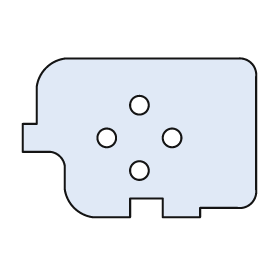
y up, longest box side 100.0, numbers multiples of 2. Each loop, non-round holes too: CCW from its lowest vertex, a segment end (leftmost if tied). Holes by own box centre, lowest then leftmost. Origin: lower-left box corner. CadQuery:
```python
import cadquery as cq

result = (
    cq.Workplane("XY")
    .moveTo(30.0, 0.0)
    .lineTo(46.0, 0.0)
    .lineTo(46.0, 8.0)
    .lineTo(60.0, 8.0)
    .lineTo(60.0, 0.0)
    .lineTo(76.0, 0.0)
    .lineTo(76.0, 4.0)
    .lineTo(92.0, 4.0)
    .threePointArc((98.0, 6.0), (100.0, 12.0))
    .lineTo(100.0, 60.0)
    .threePointArc((98.0, 66.0), (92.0, 68.0))
    .lineTo(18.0, 68.0)
    .threePointArc((10.0, 64.0), (6.0, 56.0))
    .lineTo(6.0, 40.0)
    .lineTo(0.0, 40.0)
    .lineTo(0.0, 28.0)
    .lineTo(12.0, 28.0)
    .threePointArc((16.0, 26.0), (18.0, 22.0))
    .lineTo(18.0, 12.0)
    .threePointArc((22.0, 4.0), (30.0, 0.0))
    .close()
    .moveTo(50.0, 20.0)
    .circle(4.0)
    .moveTo(36.0, 34.0)
    .circle(4.0)
    .moveTo(64.0, 34.0)
    .circle(4.0)
    .moveTo(50.0, 48.0)
    .circle(4.0)
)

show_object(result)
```